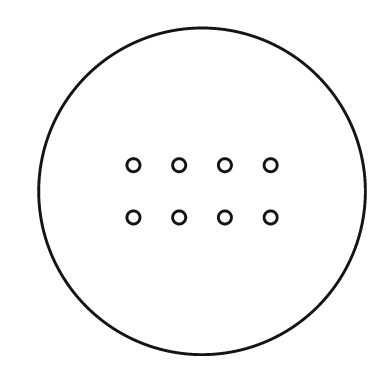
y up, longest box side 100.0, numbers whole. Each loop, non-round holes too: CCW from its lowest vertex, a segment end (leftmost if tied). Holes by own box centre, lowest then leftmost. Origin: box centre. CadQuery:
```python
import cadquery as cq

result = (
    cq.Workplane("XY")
    .moveTo(0.0, 0.0)
    .circle(50.0)
    .moveTo(-21.0, -8.0)
    .circle(2.0)
    .moveTo(-7.0, -8.0)
    .circle(2.0)
    .moveTo(7.0, -8.0)
    .circle(2.0)
    .moveTo(21.0, -8.0)
    .circle(2.0)
    .moveTo(-21.0, 8.0)
    .circle(2.0)
    .moveTo(-7.0, 8.0)
    .circle(2.0)
    .moveTo(7.0, 8.0)
    .circle(2.0)
    .moveTo(21.0, 8.0)
    .circle(2.0)
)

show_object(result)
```